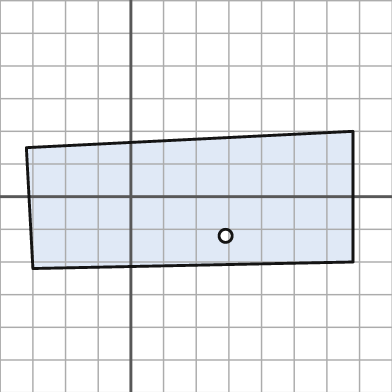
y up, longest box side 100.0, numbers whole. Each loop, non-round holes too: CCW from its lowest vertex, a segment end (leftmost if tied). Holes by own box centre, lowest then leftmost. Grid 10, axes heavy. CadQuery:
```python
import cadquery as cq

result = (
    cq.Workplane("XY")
    .moveTo(-30.0, -22.0)
    .lineTo(68.0, -20.0)
    .lineTo(68.0, 20.0)
    .lineTo(-32.0, 15.0)
    .close()
    .moveTo(29.0, -12.0)
    .circle(2.0)
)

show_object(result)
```